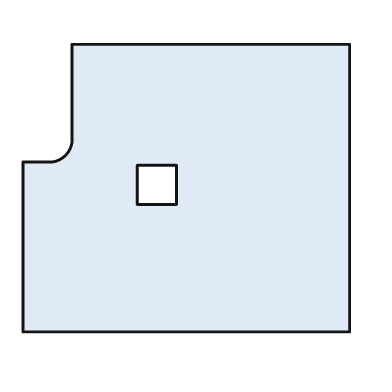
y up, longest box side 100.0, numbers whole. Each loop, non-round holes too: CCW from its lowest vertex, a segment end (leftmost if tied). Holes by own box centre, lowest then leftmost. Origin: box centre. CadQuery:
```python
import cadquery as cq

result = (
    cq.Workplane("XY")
    .moveTo(-50.0, -44.0)
    .lineTo(50.0, -44.0)
    .lineTo(50.0, 44.0)
    .lineTo(-35.0, 44.0)
    .lineTo(-35.0, 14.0)
    .threePointArc((-37.0, 10.0), (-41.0, 8.0))
    .lineTo(-50.0, 8.0)
    .close()
    .moveTo(-15.0, -5.0)
    .lineTo(-3.0, -5.0)
    .lineTo(-3.0, 7.0)
    .lineTo(-15.0, 7.0)
    .close()
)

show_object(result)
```